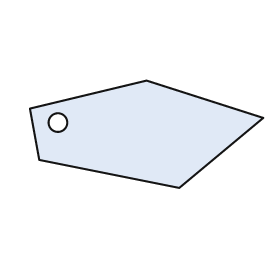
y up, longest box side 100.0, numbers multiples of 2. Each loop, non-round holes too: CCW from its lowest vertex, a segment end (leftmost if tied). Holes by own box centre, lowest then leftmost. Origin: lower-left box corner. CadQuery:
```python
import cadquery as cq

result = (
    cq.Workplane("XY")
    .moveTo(64.0, 0.0)
    .lineTo(100.0, 30.0)
    .lineTo(50.0, 46.0)
    .lineTo(0.0, 34.0)
    .lineTo(4.0, 12.0)
    .close()
    .moveTo(12.0, 28.0)
    .circle(4.0)
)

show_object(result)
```